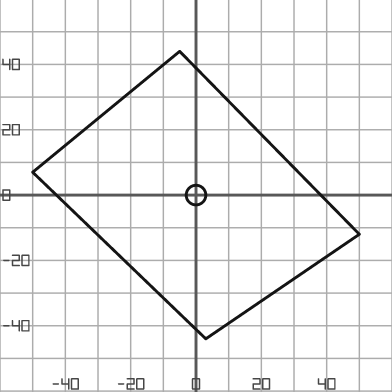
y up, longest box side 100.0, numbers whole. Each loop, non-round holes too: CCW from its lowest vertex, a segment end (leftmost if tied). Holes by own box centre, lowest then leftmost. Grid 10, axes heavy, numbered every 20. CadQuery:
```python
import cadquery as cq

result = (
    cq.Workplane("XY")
    .moveTo(3.0, -44.0)
    .lineTo(50.0, -12.0)
    .lineTo(-5.0, 44.0)
    .lineTo(-50.0, 7.0)
    .close()
    .moveTo(0.0, 0.0)
    .circle(3.0)
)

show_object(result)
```